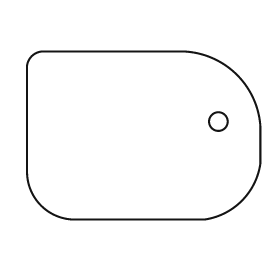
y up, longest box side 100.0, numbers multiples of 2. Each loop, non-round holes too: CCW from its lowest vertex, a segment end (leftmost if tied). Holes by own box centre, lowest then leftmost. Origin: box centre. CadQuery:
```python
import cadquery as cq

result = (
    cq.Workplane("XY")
    .moveTo(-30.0, -36.0)
    .lineTo(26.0, -36.0)
    .threePointArc((42.0, -28.0), (50.0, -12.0))
    .lineTo(50.0, 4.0)
    .threePointArc((40.0, 26.0), (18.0, 36.0))
    .lineTo(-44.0, 36.0)
    .threePointArc((-48.0, 34.0), (-50.0, 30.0))
    .lineTo(-50.0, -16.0)
    .threePointArc((-44.0, -30.0), (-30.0, -36.0))
    .close()
    .moveTo(32.0, 6.0)
    .circle(4.0)
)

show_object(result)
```